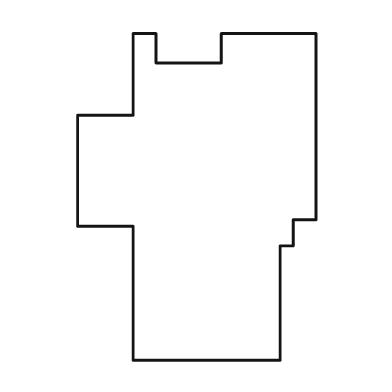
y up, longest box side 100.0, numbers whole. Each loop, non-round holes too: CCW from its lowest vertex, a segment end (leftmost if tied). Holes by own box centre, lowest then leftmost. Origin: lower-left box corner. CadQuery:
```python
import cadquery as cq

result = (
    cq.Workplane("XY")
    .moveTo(17.0, 0.0)
    .lineTo(62.0, 0.0)
    .lineTo(62.0, 35.0)
    .lineTo(66.0, 35.0)
    .lineTo(66.0, 43.0)
    .lineTo(73.0, 43.0)
    .lineTo(73.0, 100.0)
    .lineTo(44.0, 100.0)
    .lineTo(44.0, 91.0)
    .lineTo(24.0, 91.0)
    .lineTo(24.0, 100.0)
    .lineTo(17.0, 100.0)
    .lineTo(17.0, 75.0)
    .lineTo(0.0, 75.0)
    .lineTo(0.0, 41.0)
    .lineTo(17.0, 41.0)
    .close()
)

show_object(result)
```